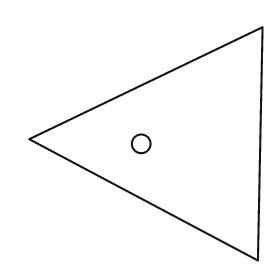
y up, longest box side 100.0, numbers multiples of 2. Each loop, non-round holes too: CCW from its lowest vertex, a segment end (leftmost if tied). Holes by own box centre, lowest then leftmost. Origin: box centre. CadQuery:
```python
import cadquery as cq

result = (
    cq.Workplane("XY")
    .moveTo(48.0, -50.0)
    .lineTo(50.0, 50.0)
    .lineTo(-50.0, 2.0)
    .close()
    .moveTo(-2.0, 0.0)
    .circle(4.0)
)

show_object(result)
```